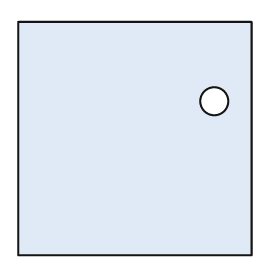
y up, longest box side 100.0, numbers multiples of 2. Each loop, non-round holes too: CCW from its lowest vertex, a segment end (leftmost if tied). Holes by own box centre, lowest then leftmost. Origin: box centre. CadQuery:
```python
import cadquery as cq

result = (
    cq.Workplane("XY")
    .moveTo(-50.0, -50.0)
    .lineTo(50.0, -50.0)
    .lineTo(50.0, 50.0)
    .lineTo(-50.0, 50.0)
    .close()
    .moveTo(34.0, 16.0)
    .circle(6.0)
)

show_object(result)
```